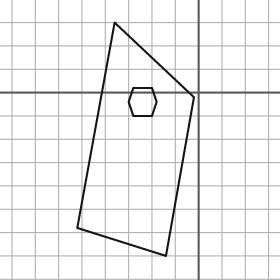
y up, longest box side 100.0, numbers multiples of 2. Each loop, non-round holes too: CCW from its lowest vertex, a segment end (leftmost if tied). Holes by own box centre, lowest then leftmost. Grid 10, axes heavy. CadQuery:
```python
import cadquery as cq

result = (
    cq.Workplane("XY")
    .moveTo(-14.0, -70.0)
    .lineTo(-2.0, -2.0)
    .lineTo(-36.0, 30.0)
    .lineTo(-52.0, -58.0)
    .close()
    .moveTo(-28.0, -10.0)
    .lineTo(-20.0, -10.0)
    .lineTo(-18.0, -4.0)
    .lineTo(-20.0, 2.0)
    .lineTo(-28.0, 2.0)
    .lineTo(-30.0, -4.0)
    .close()
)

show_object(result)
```